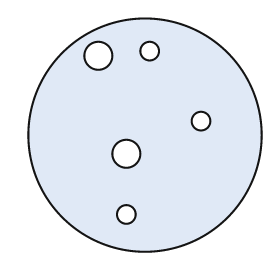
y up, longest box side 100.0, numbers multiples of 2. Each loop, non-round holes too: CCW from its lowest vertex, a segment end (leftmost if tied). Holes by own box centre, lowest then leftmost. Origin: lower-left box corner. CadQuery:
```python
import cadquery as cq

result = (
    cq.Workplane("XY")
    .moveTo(50.0, 50.0)
    .circle(50.0)
    .moveTo(42.0, 16.0)
    .circle(4.0)
    .moveTo(42.0, 42.0)
    .circle(6.0)
    .moveTo(74.0, 56.0)
    .circle(4.0)
    .moveTo(30.0, 84.0)
    .circle(6.0)
    .moveTo(52.0, 86.0)
    .circle(4.0)
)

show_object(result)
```